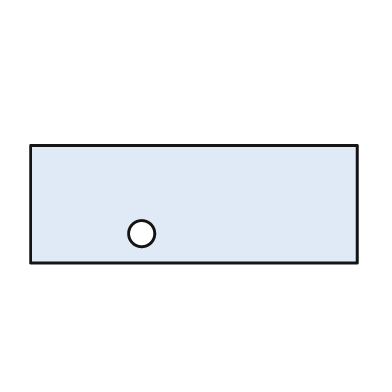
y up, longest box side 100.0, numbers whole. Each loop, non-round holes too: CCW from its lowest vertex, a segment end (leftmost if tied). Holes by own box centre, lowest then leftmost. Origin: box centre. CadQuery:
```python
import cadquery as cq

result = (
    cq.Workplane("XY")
    .moveTo(-50.0, -18.0)
    .lineTo(50.0, -18.0)
    .lineTo(50.0, 18.0)
    .lineTo(-50.0, 18.0)
    .close()
    .moveTo(-16.0, -9.0)
    .circle(4.0)
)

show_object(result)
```